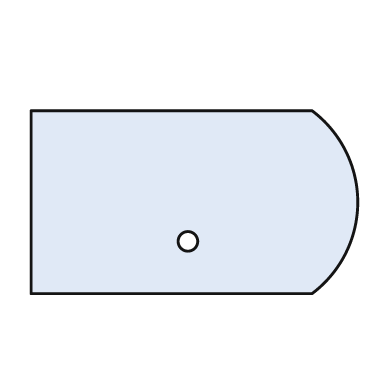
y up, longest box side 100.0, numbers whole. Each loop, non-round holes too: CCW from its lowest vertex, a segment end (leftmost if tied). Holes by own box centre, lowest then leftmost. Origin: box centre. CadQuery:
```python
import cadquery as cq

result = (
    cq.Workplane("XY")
    .moveTo(-50.0, -28.0)
    .lineTo(36.0, -28.0)
    .threePointArc((50.0, 0.0), (36.0, 28.0))
    .lineTo(-50.0, 28.0)
    .close()
    .moveTo(-2.0, -12.0)
    .circle(3.0)
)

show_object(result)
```